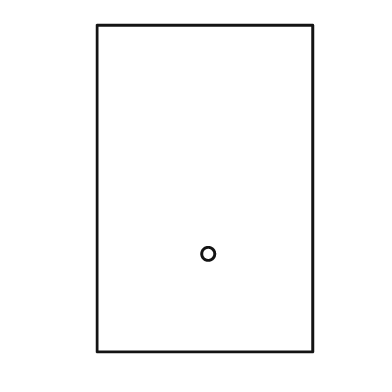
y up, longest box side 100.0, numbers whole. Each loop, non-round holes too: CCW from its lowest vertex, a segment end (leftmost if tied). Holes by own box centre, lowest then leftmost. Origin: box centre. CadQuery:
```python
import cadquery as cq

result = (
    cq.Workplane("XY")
    .moveTo(-33.0, -50.0)
    .lineTo(33.0, -50.0)
    .lineTo(33.0, 50.0)
    .lineTo(-33.0, 50.0)
    .close()
    .moveTo(1.0, -20.0)
    .circle(2.0)
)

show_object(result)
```